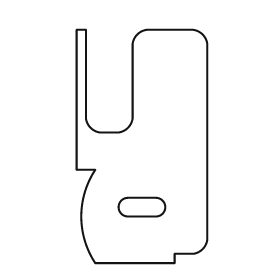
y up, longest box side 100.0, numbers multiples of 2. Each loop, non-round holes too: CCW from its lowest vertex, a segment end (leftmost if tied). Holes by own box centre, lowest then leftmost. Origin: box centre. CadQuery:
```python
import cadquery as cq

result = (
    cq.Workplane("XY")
    .moveTo(-20.0, -50.0)
    .lineTo(14.0, -50.0)
    .lineTo(14.0, -46.0)
    .lineTo(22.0, -46.0)
    .threePointArc((26.0, -44.0), (28.0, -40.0))
    .lineTo(28.0, 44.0)
    .threePointArc((26.0, 48.0), (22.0, 50.0))
    .lineTo(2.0, 50.0)
    .threePointArc((-2.0, 48.0), (-4.0, 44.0))
    .lineTo(-4.0, 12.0)
    .threePointArc((-6.0, 8.0), (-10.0, 6.0))
    .lineTo(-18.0, 6.0)
    .threePointArc((-22.0, 8.0), (-24.0, 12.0))
    .lineTo(-24.0, 50.0)
    .lineTo(-28.0, 50.0)
    .lineTo(-28.0, -10.0)
    .lineTo(-20.0, -10.0)
    .threePointArc((-26.0, -30.0), (-20.0, -50.0))
    .close()
    .moveTo(-6.0, -30.0)
    .lineTo(6.0, -30.0)
    .threePointArc((10.0, -26.0), (6.0, -22.0))
    .lineTo(-6.0, -22.0)
    .threePointArc((-10.0, -26.0), (-6.0, -30.0))
    .close()
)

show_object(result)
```